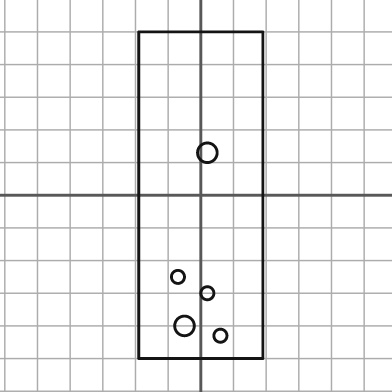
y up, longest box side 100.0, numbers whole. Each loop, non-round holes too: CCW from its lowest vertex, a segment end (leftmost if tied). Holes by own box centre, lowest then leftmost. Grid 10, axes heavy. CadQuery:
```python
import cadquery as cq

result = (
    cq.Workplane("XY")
    .moveTo(-19.0, -50.0)
    .lineTo(19.0, -50.0)
    .lineTo(19.0, 50.0)
    .lineTo(-19.0, 50.0)
    .close()
    .moveTo(6.0, -43.0)
    .circle(2.0)
    .moveTo(-5.0, -40.0)
    .circle(3.0)
    .moveTo(2.0, -30.0)
    .circle(2.0)
    .moveTo(-7.0, -25.0)
    .circle(2.0)
    .moveTo(2.0, 13.0)
    .circle(3.0)
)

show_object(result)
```